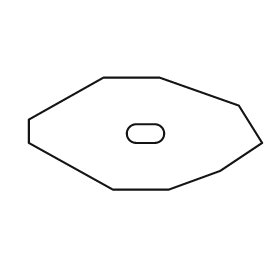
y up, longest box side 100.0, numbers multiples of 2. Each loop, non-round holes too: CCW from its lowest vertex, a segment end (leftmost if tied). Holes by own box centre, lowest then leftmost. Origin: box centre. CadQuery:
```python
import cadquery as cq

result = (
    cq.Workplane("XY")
    .moveTo(-14.0, -24.0)
    .lineTo(10.0, -24.0)
    .lineTo(32.0, -16.0)
    .lineTo(50.0, -4.0)
    .lineTo(40.0, 12.0)
    .lineTo(6.0, 24.0)
    .lineTo(-18.0, 24.0)
    .lineTo(-50.0, 6.0)
    .lineTo(-50.0, -4.0)
    .close()
    .moveTo(-4.0, -4.0)
    .lineTo(4.0, -4.0)
    .threePointArc((8.0, 0.0), (4.0, 4.0))
    .lineTo(-4.0, 4.0)
    .threePointArc((-8.0, 0.0), (-4.0, -4.0))
    .close()
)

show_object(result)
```